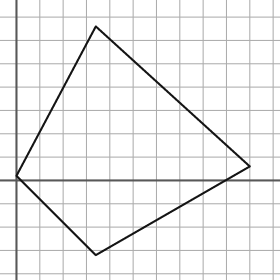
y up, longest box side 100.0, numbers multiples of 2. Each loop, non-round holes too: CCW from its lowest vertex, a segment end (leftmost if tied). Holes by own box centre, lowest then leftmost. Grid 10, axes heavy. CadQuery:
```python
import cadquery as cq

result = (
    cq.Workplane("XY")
    .moveTo(34.0, -32.0)
    .lineTo(100.0, 6.0)
    .lineTo(34.0, 66.0)
    .lineTo(0.0, 2.0)
    .close()
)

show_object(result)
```